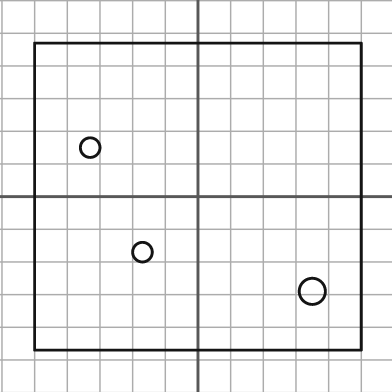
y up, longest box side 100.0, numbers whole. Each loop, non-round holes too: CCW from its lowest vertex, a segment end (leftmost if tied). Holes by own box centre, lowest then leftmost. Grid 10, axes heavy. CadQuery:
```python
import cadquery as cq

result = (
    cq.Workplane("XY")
    .moveTo(-50.0, -47.0)
    .lineTo(50.0, -47.0)
    .lineTo(50.0, 47.0)
    .lineTo(-50.0, 47.0)
    .close()
    .moveTo(35.0, -29.0)
    .circle(4.0)
    .moveTo(-17.0, -17.0)
    .circle(3.0)
    .moveTo(-33.0, 15.0)
    .circle(3.0)
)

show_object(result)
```